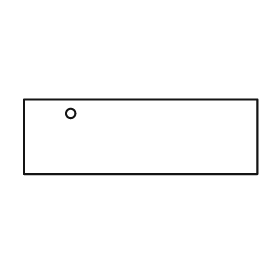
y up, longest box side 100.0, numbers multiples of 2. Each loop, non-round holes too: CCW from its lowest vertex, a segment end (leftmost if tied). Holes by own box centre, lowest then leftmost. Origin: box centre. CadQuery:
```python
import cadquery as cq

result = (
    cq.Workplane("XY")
    .moveTo(-50.0, -16.0)
    .lineTo(50.0, -16.0)
    .lineTo(50.0, 16.0)
    .lineTo(-50.0, 16.0)
    .close()
    .moveTo(-30.0, 10.0)
    .circle(2.0)
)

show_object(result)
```